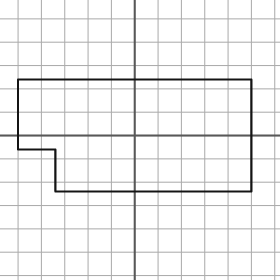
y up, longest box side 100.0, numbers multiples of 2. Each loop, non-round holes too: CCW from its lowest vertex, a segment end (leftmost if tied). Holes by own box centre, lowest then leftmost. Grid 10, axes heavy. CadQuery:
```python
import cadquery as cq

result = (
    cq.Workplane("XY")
    .moveTo(-34.0, -24.0)
    .lineTo(50.0, -24.0)
    .lineTo(50.0, 24.0)
    .lineTo(-50.0, 24.0)
    .lineTo(-50.0, -6.0)
    .lineTo(-34.0, -6.0)
    .close()
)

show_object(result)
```